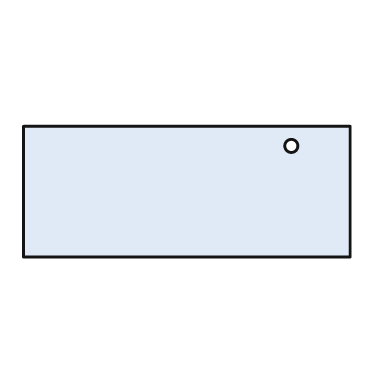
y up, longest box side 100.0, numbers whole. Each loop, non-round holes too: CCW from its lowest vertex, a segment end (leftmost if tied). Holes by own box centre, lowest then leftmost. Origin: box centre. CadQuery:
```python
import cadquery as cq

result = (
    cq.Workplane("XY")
    .moveTo(-50.0, -20.0)
    .lineTo(50.0, -20.0)
    .lineTo(50.0, 20.0)
    .lineTo(-50.0, 20.0)
    .close()
    .moveTo(32.0, 14.0)
    .circle(2.0)
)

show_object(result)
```